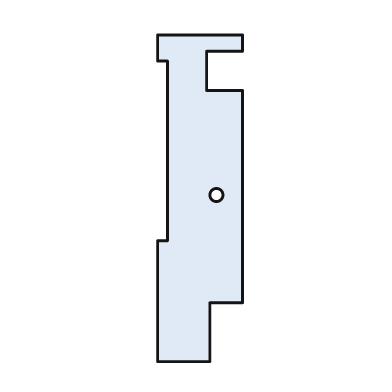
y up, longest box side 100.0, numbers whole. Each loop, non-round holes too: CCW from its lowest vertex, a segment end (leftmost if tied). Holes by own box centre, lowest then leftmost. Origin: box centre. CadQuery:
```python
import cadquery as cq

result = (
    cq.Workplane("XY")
    .moveTo(-13.0, -50.0)
    .lineTo(3.0, -50.0)
    .lineTo(3.0, -32.0)
    .lineTo(13.0, -32.0)
    .lineTo(13.0, 33.0)
    .lineTo(2.0, 33.0)
    .lineTo(2.0, 45.0)
    .lineTo(13.0, 45.0)
    .lineTo(13.0, 50.0)
    .lineTo(-13.0, 50.0)
    .lineTo(-13.0, 42.0)
    .lineTo(-10.0, 42.0)
    .lineTo(-10.0, -13.0)
    .lineTo(-13.0, -13.0)
    .close()
    .moveTo(5.0, 1.0)
    .circle(2.0)
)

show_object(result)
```